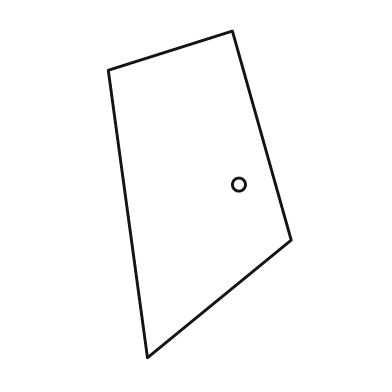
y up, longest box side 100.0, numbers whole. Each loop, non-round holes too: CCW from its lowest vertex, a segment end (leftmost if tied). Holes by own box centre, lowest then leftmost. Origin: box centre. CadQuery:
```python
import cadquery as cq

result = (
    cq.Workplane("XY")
    .moveTo(-16.0, -50.0)
    .lineTo(28.0, -14.0)
    .lineTo(10.0, 50.0)
    .lineTo(-28.0, 38.0)
    .close()
    .moveTo(12.0, 3.0)
    .circle(2.0)
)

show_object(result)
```